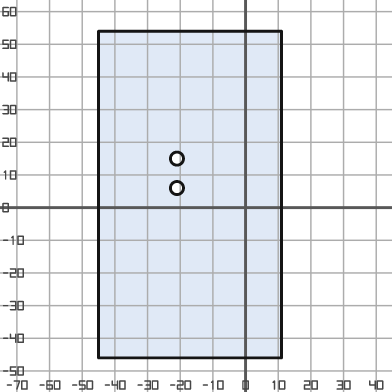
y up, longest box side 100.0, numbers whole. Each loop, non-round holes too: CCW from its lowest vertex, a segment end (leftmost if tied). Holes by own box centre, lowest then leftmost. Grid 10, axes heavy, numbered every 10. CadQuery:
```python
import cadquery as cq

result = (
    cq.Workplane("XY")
    .moveTo(-45.0, -46.0)
    .lineTo(11.0, -46.0)
    .lineTo(11.0, 54.0)
    .lineTo(-45.0, 54.0)
    .close()
    .moveTo(-21.0, 6.0)
    .circle(2.0)
    .moveTo(-21.0, 15.0)
    .circle(2.0)
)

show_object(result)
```